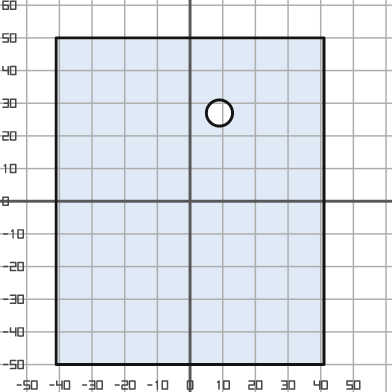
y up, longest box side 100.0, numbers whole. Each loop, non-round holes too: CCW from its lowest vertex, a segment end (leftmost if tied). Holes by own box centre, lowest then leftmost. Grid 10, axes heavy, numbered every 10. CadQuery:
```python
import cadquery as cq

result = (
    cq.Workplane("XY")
    .moveTo(-41.0, -50.0)
    .lineTo(41.0, -50.0)
    .lineTo(41.0, 50.0)
    .lineTo(-41.0, 50.0)
    .close()
    .moveTo(9.0, 27.0)
    .circle(4.0)
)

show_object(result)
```